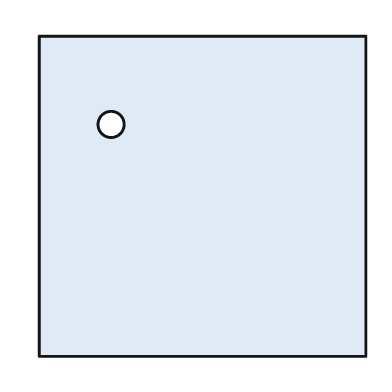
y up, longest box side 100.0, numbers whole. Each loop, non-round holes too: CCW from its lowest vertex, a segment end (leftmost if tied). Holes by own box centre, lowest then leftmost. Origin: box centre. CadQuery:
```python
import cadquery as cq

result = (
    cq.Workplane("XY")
    .moveTo(-50.0, -49.0)
    .lineTo(50.0, -49.0)
    .lineTo(50.0, 49.0)
    .lineTo(-50.0, 49.0)
    .close()
    .moveTo(-28.0, 22.0)
    .circle(4.0)
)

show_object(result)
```